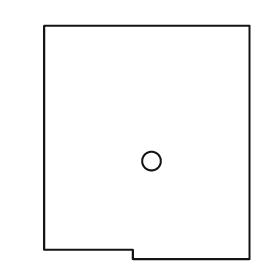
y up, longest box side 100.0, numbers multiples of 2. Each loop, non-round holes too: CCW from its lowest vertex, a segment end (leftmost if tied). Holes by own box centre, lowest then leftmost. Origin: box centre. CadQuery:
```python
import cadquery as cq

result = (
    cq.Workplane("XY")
    .moveTo(-6.0, -50.0)
    .lineTo(44.0, -50.0)
    .lineTo(44.0, 50.0)
    .lineTo(-44.0, 50.0)
    .lineTo(-44.0, -46.0)
    .lineTo(-6.0, -46.0)
    .close()
    .moveTo(2.0, -8.0)
    .circle(4.0)
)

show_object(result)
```